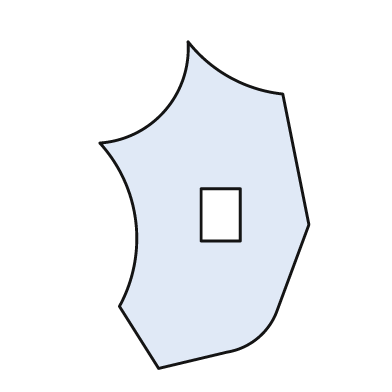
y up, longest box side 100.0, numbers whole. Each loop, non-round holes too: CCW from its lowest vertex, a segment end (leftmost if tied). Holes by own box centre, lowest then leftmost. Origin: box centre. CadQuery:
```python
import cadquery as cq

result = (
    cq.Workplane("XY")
    .moveTo(-14.0, -50.0)
    .lineTo(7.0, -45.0)
    .threePointArc((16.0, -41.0), (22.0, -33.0))
    .lineTo(32.0, -6.0)
    .lineTo(24.0, 34.0)
    .threePointArc((8.0, 39.0), (-5.0, 50.0))
    .threePointArc((-12.0, 29.0), (-32.0, 19.0))
    .threePointArc((-21.0, -5.0), (-26.0, -31.0))
    .close()
    .moveTo(-1.0, -11.0)
    .lineTo(11.0, -11.0)
    .lineTo(11.0, 5.0)
    .lineTo(-1.0, 5.0)
    .close()
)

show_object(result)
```